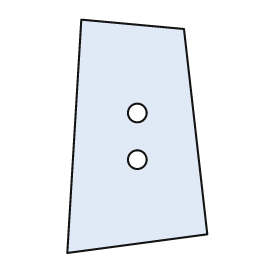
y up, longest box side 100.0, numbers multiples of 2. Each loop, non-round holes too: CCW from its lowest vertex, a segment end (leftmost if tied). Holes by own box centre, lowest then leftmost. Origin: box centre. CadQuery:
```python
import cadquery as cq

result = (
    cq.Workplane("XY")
    .moveTo(-30.0, -50.0)
    .lineTo(30.0, -42.0)
    .lineTo(20.0, 46.0)
    .lineTo(-24.0, 50.0)
    .close()
    .moveTo(0.0, -10.0)
    .circle(4.0)
    .moveTo(0.0, 10.0)
    .circle(4.0)
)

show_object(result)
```